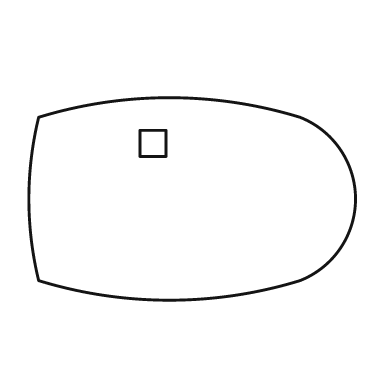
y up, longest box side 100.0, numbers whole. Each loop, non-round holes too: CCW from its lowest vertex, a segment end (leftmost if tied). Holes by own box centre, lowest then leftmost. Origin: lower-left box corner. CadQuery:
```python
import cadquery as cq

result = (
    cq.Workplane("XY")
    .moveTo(3.0, 6.0)
    .threePointArc((43.0, 0.0), (83.0, 6.0))
    .threePointArc((100.0, 31.0), (83.0, 56.0))
    .threePointArc((43.0, 62.0), (3.0, 56.0))
    .threePointArc((0.0, 31.0), (3.0, 6.0))
    .close()
    .moveTo(34.0, 44.0)
    .lineTo(42.0, 44.0)
    .lineTo(42.0, 52.0)
    .lineTo(34.0, 52.0)
    .close()
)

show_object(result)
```